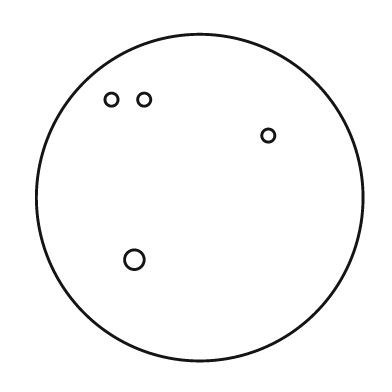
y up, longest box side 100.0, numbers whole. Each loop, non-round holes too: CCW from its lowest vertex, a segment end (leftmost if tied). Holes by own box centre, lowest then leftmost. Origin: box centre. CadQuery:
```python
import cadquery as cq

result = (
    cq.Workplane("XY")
    .moveTo(0.0, 0.0)
    .circle(50.0)
    .moveTo(-20.0, -19.0)
    .circle(3.0)
    .moveTo(21.0, 19.0)
    .circle(2.0)
    .moveTo(-27.0, 30.0)
    .circle(2.0)
    .moveTo(-17.0, 30.0)
    .circle(2.0)
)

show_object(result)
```